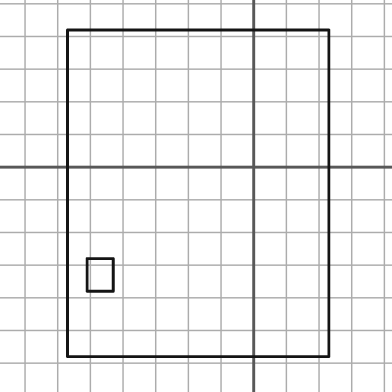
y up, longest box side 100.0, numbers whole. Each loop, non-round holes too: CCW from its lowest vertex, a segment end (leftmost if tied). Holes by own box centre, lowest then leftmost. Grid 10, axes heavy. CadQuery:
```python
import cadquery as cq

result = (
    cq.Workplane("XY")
    .moveTo(-57.0, -58.0)
    .lineTo(23.0, -58.0)
    .lineTo(23.0, 42.0)
    .lineTo(-57.0, 42.0)
    .close()
    .moveTo(-51.0, -38.0)
    .lineTo(-43.0, -38.0)
    .lineTo(-43.0, -28.0)
    .lineTo(-51.0, -28.0)
    .close()
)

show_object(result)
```